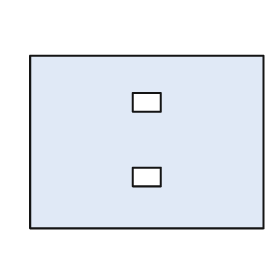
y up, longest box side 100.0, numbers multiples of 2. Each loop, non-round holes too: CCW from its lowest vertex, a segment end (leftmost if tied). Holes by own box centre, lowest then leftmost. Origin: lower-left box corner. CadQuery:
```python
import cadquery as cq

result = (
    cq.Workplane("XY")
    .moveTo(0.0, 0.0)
    .lineTo(100.0, 0.0)
    .lineTo(100.0, 74.0)
    .lineTo(0.0, 74.0)
    .close()
    .moveTo(44.0, 18.0)
    .lineTo(56.0, 18.0)
    .lineTo(56.0, 26.0)
    .lineTo(44.0, 26.0)
    .close()
    .moveTo(44.0, 50.0)
    .lineTo(56.0, 50.0)
    .lineTo(56.0, 58.0)
    .lineTo(44.0, 58.0)
    .close()
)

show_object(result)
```